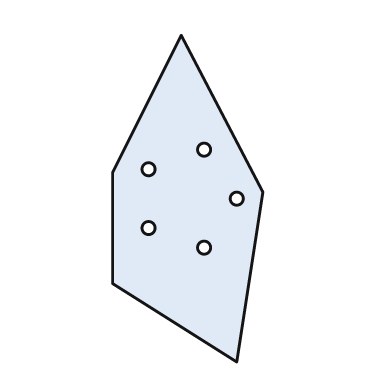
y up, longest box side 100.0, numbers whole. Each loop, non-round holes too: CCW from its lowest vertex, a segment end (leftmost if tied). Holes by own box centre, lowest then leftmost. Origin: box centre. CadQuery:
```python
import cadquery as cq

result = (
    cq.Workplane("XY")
    .moveTo(15.0, -50.0)
    .lineTo(23.0, 2.0)
    .lineTo(-2.0, 50.0)
    .lineTo(-23.0, 8.0)
    .lineTo(-23.0, -26.0)
    .close()
    .moveTo(5.0, -15.0)
    .circle(2.0)
    .moveTo(-12.0, -9.0)
    .circle(2.0)
    .moveTo(15.0, 0.0)
    .circle(2.0)
    .moveTo(-12.0, 9.0)
    .circle(2.0)
    .moveTo(5.0, 15.0)
    .circle(2.0)
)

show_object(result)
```